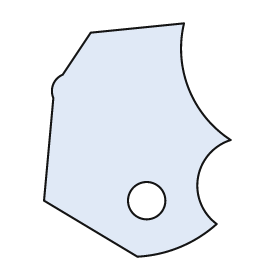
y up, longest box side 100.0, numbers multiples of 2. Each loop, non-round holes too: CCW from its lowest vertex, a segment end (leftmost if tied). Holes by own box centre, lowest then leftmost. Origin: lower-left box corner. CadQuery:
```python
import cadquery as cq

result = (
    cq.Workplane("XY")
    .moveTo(40.0, 0.0)
    .threePointArc((58.0, 4.0), (74.0, 14.0))
    .threePointArc((66.0, 34.0), (80.0, 50.0))
    .threePointArc((62.0, 72.0), (60.0, 100.0))
    .lineTo(20.0, 96.0)
    .lineTo(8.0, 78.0)
    .threePointArc((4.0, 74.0), (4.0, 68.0))
    .lineTo(0.0, 24.0)
    .close()
    .moveTo(44.0, 24.0)
    .circle(8.0)
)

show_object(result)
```